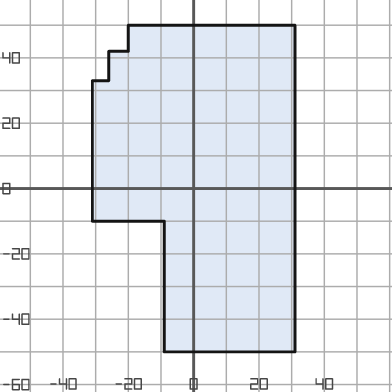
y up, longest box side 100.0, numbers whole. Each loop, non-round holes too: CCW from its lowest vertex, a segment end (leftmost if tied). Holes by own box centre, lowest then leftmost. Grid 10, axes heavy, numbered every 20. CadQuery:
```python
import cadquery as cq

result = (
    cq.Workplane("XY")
    .moveTo(-9.0, -50.0)
    .lineTo(31.0, -50.0)
    .lineTo(31.0, 50.0)
    .lineTo(-20.0, 50.0)
    .lineTo(-20.0, 42.0)
    .lineTo(-26.0, 42.0)
    .lineTo(-26.0, 33.0)
    .lineTo(-31.0, 33.0)
    .lineTo(-31.0, -10.0)
    .lineTo(-9.0, -10.0)
    .close()
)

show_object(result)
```